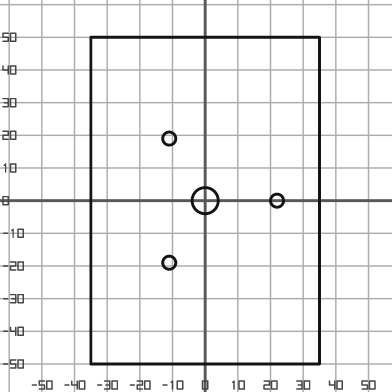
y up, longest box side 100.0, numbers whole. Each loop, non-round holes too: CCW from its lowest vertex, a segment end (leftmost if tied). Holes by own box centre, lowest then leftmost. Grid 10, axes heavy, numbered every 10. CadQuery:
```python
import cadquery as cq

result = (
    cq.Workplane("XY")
    .moveTo(-35.0, -50.0)
    .lineTo(35.0, -50.0)
    .lineTo(35.0, 50.0)
    .lineTo(-35.0, 50.0)
    .close()
    .moveTo(-11.0, -19.0)
    .circle(2.0)
    .moveTo(0.0, 0.0)
    .circle(4.0)
    .moveTo(22.0, 0.0)
    .circle(2.0)
    .moveTo(-11.0, 19.0)
    .circle(2.0)
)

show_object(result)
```